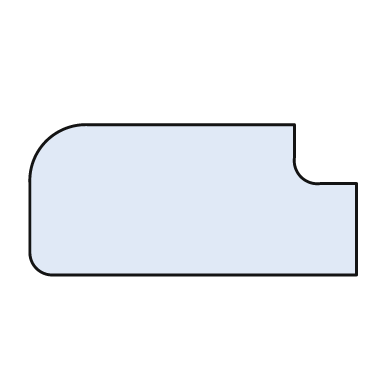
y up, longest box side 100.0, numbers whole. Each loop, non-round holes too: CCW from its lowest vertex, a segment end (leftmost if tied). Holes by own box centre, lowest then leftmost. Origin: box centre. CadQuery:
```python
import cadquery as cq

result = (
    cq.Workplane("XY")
    .moveTo(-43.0, -23.0)
    .lineTo(50.0, -23.0)
    .lineTo(50.0, 5.0)
    .lineTo(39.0, 5.0)
    .threePointArc((33.0, 7.0), (31.0, 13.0))
    .lineTo(31.0, 23.0)
    .lineTo(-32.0, 23.0)
    .threePointArc((-45.0, 18.0), (-50.0, 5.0))
    .lineTo(-50.0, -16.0)
    .threePointArc((-48.0, -21.0), (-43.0, -23.0))
    .close()
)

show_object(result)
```